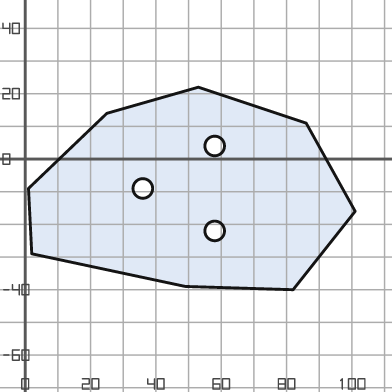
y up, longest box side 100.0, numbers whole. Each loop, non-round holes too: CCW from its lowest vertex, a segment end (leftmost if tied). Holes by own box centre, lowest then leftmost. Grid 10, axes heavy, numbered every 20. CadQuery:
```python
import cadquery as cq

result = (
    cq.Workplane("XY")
    .moveTo(82.0, -40.0)
    .lineTo(101.0, -16.0)
    .lineTo(86.0, 11.0)
    .lineTo(53.0, 22.0)
    .lineTo(25.0, 14.0)
    .lineTo(1.0, -9.0)
    .lineTo(2.0, -29.0)
    .lineTo(49.0, -39.0)
    .close()
    .moveTo(58.0, -22.0)
    .circle(3.0)
    .moveTo(36.0, -9.0)
    .circle(3.0)
    .moveTo(58.0, 4.0)
    .circle(3.0)
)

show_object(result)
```